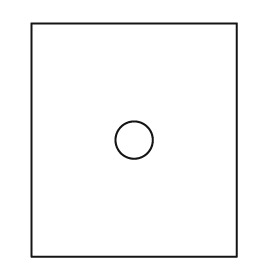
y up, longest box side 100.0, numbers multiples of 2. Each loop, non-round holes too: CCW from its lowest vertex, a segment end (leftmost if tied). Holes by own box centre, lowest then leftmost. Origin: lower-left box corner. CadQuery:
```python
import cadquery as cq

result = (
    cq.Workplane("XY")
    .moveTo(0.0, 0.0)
    .lineTo(88.0, 0.0)
    .lineTo(88.0, 100.0)
    .lineTo(0.0, 100.0)
    .close()
    .moveTo(44.0, 50.0)
    .circle(8.0)
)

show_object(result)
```